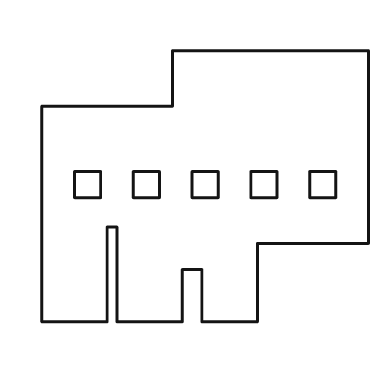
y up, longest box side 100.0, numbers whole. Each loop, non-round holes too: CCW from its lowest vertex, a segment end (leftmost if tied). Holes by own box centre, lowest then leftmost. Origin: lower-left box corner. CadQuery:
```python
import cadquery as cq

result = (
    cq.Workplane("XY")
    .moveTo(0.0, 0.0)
    .lineTo(20.0, 0.0)
    .lineTo(20.0, 29.0)
    .lineTo(23.0, 29.0)
    .lineTo(23.0, 0.0)
    .lineTo(43.0, 0.0)
    .lineTo(43.0, 16.0)
    .lineTo(49.0, 16.0)
    .lineTo(49.0, 0.0)
    .lineTo(66.0, 0.0)
    .lineTo(66.0, 24.0)
    .lineTo(100.0, 24.0)
    .lineTo(100.0, 83.0)
    .lineTo(40.0, 83.0)
    .lineTo(40.0, 66.0)
    .lineTo(0.0, 66.0)
    .close()
    .moveTo(10.0, 38.0)
    .lineTo(18.0, 38.0)
    .lineTo(18.0, 46.0)
    .lineTo(10.0, 46.0)
    .close()
    .moveTo(28.0, 38.0)
    .lineTo(36.0, 38.0)
    .lineTo(36.0, 46.0)
    .lineTo(28.0, 46.0)
    .close()
    .moveTo(46.0, 38.0)
    .lineTo(54.0, 38.0)
    .lineTo(54.0, 46.0)
    .lineTo(46.0, 46.0)
    .close()
    .moveTo(64.0, 38.0)
    .lineTo(72.0, 38.0)
    .lineTo(72.0, 46.0)
    .lineTo(64.0, 46.0)
    .close()
    .moveTo(82.0, 38.0)
    .lineTo(90.0, 38.0)
    .lineTo(90.0, 46.0)
    .lineTo(82.0, 46.0)
    .close()
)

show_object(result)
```